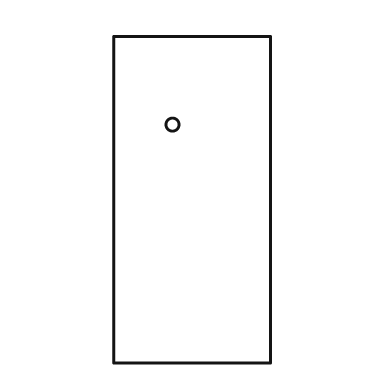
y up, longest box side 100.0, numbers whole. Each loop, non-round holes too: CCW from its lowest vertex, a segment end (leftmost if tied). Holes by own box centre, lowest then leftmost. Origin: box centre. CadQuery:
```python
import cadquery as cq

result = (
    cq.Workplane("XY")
    .moveTo(-24.0, -50.0)
    .lineTo(24.0, -50.0)
    .lineTo(24.0, 50.0)
    .lineTo(-24.0, 50.0)
    .close()
    .moveTo(-6.0, 23.0)
    .circle(2.0)
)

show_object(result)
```